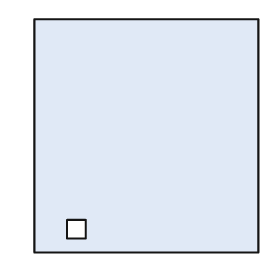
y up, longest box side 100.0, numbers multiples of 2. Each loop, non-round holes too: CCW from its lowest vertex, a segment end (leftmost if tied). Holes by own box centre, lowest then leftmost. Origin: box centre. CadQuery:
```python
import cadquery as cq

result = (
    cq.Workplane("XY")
    .moveTo(-48.0, -50.0)
    .lineTo(48.0, -50.0)
    .lineTo(48.0, 50.0)
    .lineTo(-48.0, 50.0)
    .close()
    .moveTo(-34.0, -44.0)
    .lineTo(-26.0, -44.0)
    .lineTo(-26.0, -36.0)
    .lineTo(-34.0, -36.0)
    .close()
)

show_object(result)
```